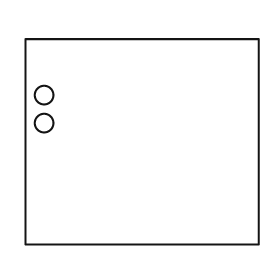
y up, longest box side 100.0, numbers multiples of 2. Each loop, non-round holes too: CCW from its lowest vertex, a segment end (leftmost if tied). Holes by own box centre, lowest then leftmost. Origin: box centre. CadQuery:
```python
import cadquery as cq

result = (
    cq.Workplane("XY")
    .moveTo(-50.0, -44.0)
    .lineTo(50.0, -44.0)
    .lineTo(50.0, 44.0)
    .lineTo(-50.0, 44.0)
    .close()
    .moveTo(-42.0, 8.0)
    .circle(4.0)
    .moveTo(-42.0, 20.0)
    .circle(4.0)
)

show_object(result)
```